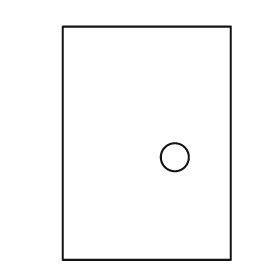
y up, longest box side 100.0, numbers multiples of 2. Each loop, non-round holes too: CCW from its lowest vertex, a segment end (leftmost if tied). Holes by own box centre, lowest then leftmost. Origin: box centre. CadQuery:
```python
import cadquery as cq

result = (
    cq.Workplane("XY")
    .moveTo(-36.0, -50.0)
    .lineTo(36.0, -50.0)
    .lineTo(36.0, 50.0)
    .lineTo(-36.0, 50.0)
    .close()
    .moveTo(12.0, -6.0)
    .circle(6.0)
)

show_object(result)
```